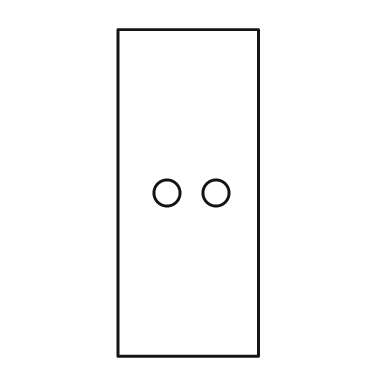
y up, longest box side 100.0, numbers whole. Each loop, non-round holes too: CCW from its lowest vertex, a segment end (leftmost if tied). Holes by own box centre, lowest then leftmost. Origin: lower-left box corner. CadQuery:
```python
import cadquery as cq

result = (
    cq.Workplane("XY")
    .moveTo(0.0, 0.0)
    .lineTo(43.0, 0.0)
    .lineTo(43.0, 100.0)
    .lineTo(0.0, 100.0)
    .close()
    .moveTo(15.0, 50.0)
    .circle(4.0)
    .moveTo(30.0, 50.0)
    .circle(4.0)
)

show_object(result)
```